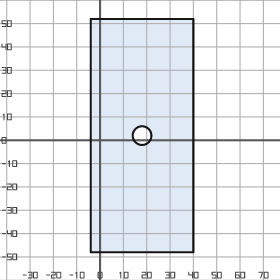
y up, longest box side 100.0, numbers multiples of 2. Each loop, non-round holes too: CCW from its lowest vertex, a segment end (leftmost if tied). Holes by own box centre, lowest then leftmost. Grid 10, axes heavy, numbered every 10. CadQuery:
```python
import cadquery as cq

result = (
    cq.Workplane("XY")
    .moveTo(-4.0, -48.0)
    .lineTo(40.0, -48.0)
    .lineTo(40.0, 52.0)
    .lineTo(-4.0, 52.0)
    .close()
    .moveTo(18.0, 2.0)
    .circle(4.0)
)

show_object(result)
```